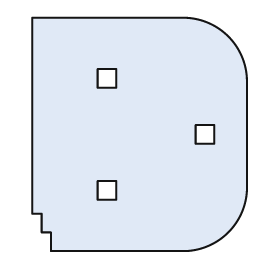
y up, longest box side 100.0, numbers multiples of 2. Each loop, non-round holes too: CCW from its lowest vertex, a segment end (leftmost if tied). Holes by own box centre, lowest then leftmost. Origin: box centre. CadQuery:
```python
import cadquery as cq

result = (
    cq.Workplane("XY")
    .moveTo(-38.0, -50.0)
    .lineTo(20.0, -50.0)
    .threePointArc((38.0, -42.0), (46.0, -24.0))
    .lineTo(46.0, 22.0)
    .threePointArc((38.0, 42.0), (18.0, 50.0))
    .lineTo(-46.0, 50.0)
    .lineTo(-46.0, -34.0)
    .lineTo(-42.0, -34.0)
    .lineTo(-42.0, -42.0)
    .lineTo(-38.0, -42.0)
    .close()
    .moveTo(-18.0, -28.0)
    .lineTo(-10.0, -28.0)
    .lineTo(-10.0, -20.0)
    .lineTo(-18.0, -20.0)
    .close()
    .moveTo(24.0, -4.0)
    .lineTo(32.0, -4.0)
    .lineTo(32.0, 4.0)
    .lineTo(24.0, 4.0)
    .close()
    .moveTo(-18.0, 20.0)
    .lineTo(-10.0, 20.0)
    .lineTo(-10.0, 28.0)
    .lineTo(-18.0, 28.0)
    .close()
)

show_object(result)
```